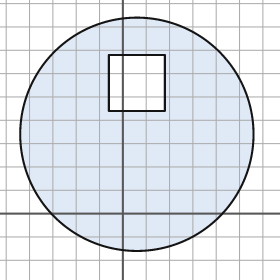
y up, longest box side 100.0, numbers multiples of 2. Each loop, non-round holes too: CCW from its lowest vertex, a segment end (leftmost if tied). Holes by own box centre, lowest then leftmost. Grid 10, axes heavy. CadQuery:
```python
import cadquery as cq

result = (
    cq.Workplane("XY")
    .moveTo(6.0, 34.0)
    .circle(50.0)
    .moveTo(-6.0, 44.0)
    .lineTo(18.0, 44.0)
    .lineTo(18.0, 68.0)
    .lineTo(-6.0, 68.0)
    .close()
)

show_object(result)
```